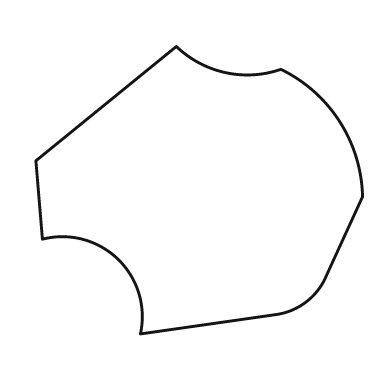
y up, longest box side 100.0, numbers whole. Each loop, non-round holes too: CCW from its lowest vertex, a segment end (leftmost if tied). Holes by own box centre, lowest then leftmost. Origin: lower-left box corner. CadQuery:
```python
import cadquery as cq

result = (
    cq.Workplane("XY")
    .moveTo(32.0, 0.0)
    .lineTo(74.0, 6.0)
    .threePointArc((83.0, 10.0), (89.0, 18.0))
    .lineTo(100.0, 42.0)
    .threePointArc((93.0, 65.0), (75.0, 81.0))
    .threePointArc((58.0, 80.0), (43.0, 88.0))
    .lineTo(0.0, 53.0)
    .lineTo(2.0, 29.0)
    .threePointArc((25.0, 23.0), (32.0, 0.0))
    .close()
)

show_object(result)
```